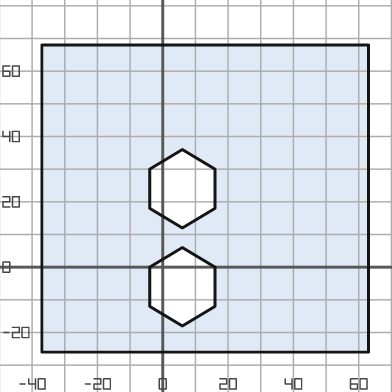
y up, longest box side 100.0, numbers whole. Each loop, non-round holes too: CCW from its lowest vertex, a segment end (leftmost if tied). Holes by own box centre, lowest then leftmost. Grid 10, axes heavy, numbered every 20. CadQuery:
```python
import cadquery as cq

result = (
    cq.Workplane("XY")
    .moveTo(-37.0, -26.0)
    .lineTo(63.0, -26.0)
    .lineTo(63.0, 68.0)
    .lineTo(-37.0, 68.0)
    .close()
    .moveTo(6.0, -18.0)
    .lineTo(16.0, -12.0)
    .lineTo(16.0, 0.0)
    .lineTo(6.0, 6.0)
    .lineTo(-4.0, 0.0)
    .lineTo(-4.0, -12.0)
    .close()
    .moveTo(6.0, 12.0)
    .lineTo(16.0, 18.0)
    .lineTo(16.0, 30.0)
    .lineTo(6.0, 36.0)
    .lineTo(-4.0, 30.0)
    .lineTo(-4.0, 18.0)
    .close()
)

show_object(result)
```